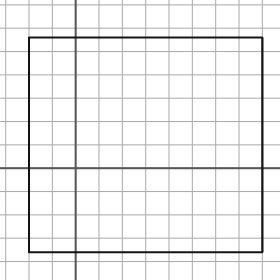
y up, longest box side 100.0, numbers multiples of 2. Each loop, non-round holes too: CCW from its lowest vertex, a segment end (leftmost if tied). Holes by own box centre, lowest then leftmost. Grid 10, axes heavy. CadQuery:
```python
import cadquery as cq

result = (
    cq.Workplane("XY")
    .moveTo(-20.0, -36.0)
    .lineTo(80.0, -36.0)
    .lineTo(80.0, 56.0)
    .lineTo(-20.0, 56.0)
    .close()
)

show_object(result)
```